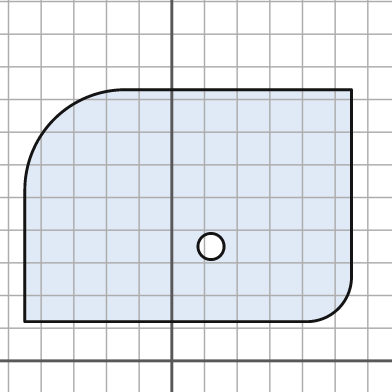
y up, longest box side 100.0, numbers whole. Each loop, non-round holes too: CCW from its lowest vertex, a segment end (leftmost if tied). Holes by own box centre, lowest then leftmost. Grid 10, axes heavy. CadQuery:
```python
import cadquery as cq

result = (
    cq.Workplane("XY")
    .moveTo(-45.0, 12.0)
    .lineTo(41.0, 12.0)
    .threePointArc((51.0, 16.0), (55.0, 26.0))
    .lineTo(55.0, 83.0)
    .lineTo(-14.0, 83.0)
    .threePointArc((-36.0, 74.0), (-45.0, 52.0))
    .close()
    .moveTo(12.0, 35.0)
    .circle(4.0)
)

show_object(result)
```